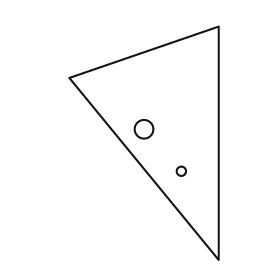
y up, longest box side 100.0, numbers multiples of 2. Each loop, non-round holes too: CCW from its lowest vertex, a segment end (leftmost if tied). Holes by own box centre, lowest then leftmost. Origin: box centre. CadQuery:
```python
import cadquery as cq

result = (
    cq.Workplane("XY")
    .moveTo(32.0, -50.0)
    .lineTo(32.0, 50.0)
    .lineTo(-32.0, 28.0)
    .close()
    .moveTo(16.0, -12.0)
    .circle(2.0)
    .moveTo(0.0, 6.0)
    .circle(4.0)
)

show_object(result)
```